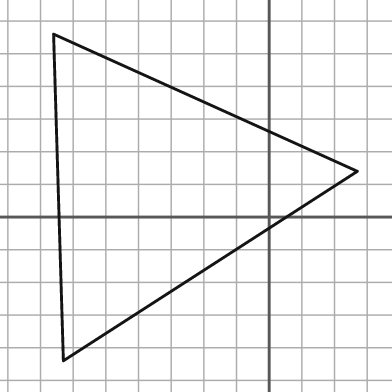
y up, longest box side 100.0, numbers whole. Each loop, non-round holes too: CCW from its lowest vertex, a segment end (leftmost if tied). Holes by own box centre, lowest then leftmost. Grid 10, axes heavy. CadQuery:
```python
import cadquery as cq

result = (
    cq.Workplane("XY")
    .moveTo(-63.0, -44.0)
    .lineTo(27.0, 14.0)
    .lineTo(-66.0, 56.0)
    .close()
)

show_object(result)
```